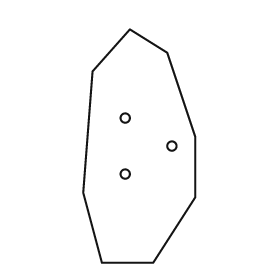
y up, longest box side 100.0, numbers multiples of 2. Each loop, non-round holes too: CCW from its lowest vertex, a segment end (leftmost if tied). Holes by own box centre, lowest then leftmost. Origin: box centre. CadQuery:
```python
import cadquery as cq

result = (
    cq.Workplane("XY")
    .moveTo(-16.0, -50.0)
    .lineTo(6.0, -50.0)
    .lineTo(24.0, -22.0)
    .lineTo(24.0, 4.0)
    .lineTo(12.0, 40.0)
    .lineTo(-4.0, 50.0)
    .lineTo(-20.0, 32.0)
    .lineTo(-24.0, -20.0)
    .close()
    .moveTo(-6.0, -12.0)
    .circle(2.0)
    .moveTo(14.0, 0.0)
    .circle(2.0)
    .moveTo(-6.0, 12.0)
    .circle(2.0)
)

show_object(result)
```